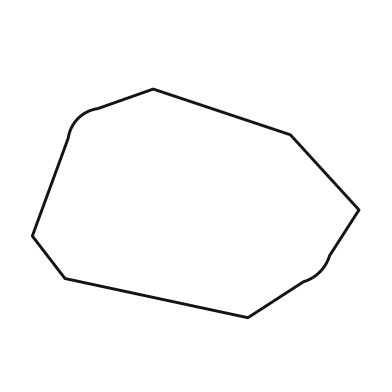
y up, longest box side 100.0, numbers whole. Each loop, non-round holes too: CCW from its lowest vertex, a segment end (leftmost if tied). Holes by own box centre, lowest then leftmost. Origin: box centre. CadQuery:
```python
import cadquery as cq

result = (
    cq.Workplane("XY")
    .moveTo(16.0, -35.0)
    .lineTo(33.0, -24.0)
    .threePointArc((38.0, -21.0), (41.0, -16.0))
    .lineTo(50.0, -2.0)
    .lineTo(29.0, 21.0)
    .lineTo(-13.0, 35.0)
    .lineTo(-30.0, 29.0)
    .threePointArc((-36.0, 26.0), (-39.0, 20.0))
    .lineTo(-50.0, -10.0)
    .lineTo(-40.0, -23.0)
    .close()
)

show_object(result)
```